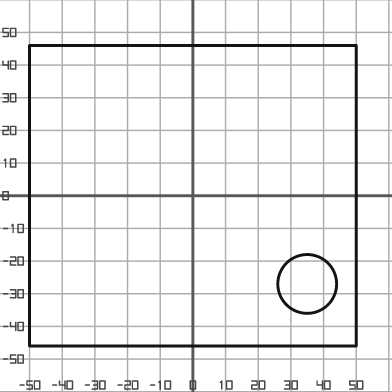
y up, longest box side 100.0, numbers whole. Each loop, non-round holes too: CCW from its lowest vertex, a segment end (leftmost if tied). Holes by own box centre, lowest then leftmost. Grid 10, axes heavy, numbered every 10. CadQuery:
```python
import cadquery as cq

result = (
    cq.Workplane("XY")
    .moveTo(-50.0, -46.0)
    .lineTo(50.0, -46.0)
    .lineTo(50.0, 46.0)
    .lineTo(-50.0, 46.0)
    .close()
    .moveTo(35.0, -27.0)
    .circle(9.0)
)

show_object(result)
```